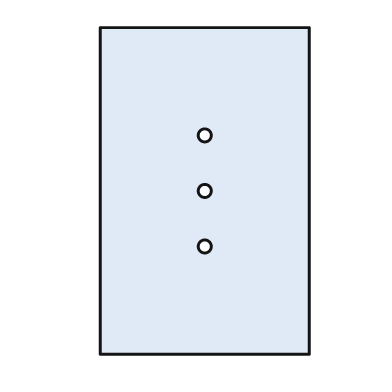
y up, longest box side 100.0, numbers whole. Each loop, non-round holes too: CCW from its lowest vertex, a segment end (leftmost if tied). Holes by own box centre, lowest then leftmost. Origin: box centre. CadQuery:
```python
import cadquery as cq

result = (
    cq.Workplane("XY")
    .moveTo(-32.0, -50.0)
    .lineTo(32.0, -50.0)
    .lineTo(32.0, 50.0)
    .lineTo(-32.0, 50.0)
    .close()
    .moveTo(0.0, -17.0)
    .circle(2.0)
    .moveTo(0.0, 0.0)
    .circle(2.0)
    .moveTo(0.0, 17.0)
    .circle(2.0)
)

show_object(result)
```